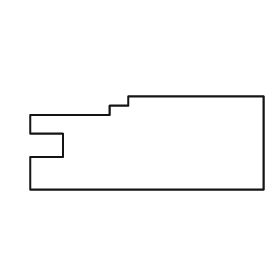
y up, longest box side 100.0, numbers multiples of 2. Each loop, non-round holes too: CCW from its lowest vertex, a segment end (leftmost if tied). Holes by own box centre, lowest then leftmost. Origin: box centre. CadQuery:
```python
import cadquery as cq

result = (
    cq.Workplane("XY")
    .moveTo(-50.0, -20.0)
    .lineTo(50.0, -20.0)
    .lineTo(50.0, 20.0)
    .lineTo(-8.0, 20.0)
    .lineTo(-8.0, 16.0)
    .lineTo(-16.0, 16.0)
    .lineTo(-16.0, 12.0)
    .lineTo(-50.0, 12.0)
    .lineTo(-50.0, 4.0)
    .lineTo(-36.0, 4.0)
    .lineTo(-36.0, -6.0)
    .lineTo(-50.0, -6.0)
    .close()
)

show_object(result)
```